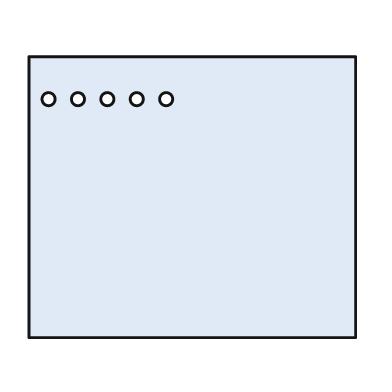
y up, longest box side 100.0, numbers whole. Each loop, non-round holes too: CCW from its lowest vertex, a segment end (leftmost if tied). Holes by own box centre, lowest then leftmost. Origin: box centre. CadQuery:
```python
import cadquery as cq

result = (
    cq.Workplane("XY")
    .moveTo(-50.0, -43.0)
    .lineTo(50.0, -43.0)
    .lineTo(50.0, 43.0)
    .lineTo(-50.0, 43.0)
    .close()
    .moveTo(-44.0, 30.0)
    .circle(2.0)
    .moveTo(-35.0, 30.0)
    .circle(2.0)
    .moveTo(-26.0, 30.0)
    .circle(2.0)
    .moveTo(-17.0, 30.0)
    .circle(2.0)
    .moveTo(-8.0, 30.0)
    .circle(2.0)
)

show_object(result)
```